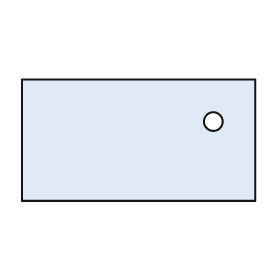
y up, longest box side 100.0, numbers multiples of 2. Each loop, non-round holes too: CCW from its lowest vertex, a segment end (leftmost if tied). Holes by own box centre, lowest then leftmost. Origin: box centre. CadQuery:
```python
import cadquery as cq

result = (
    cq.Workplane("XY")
    .moveTo(-50.0, -26.0)
    .lineTo(50.0, -26.0)
    .lineTo(50.0, 26.0)
    .lineTo(-50.0, 26.0)
    .close()
    .moveTo(32.0, 8.0)
    .circle(4.0)
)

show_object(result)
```